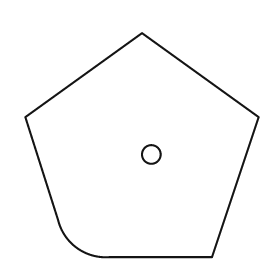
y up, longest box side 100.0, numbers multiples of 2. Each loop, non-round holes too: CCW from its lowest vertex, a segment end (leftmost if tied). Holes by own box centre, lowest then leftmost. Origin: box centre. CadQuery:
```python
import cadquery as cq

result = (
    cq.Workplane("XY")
    .moveTo(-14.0, -48.0)
    .lineTo(30.0, -48.0)
    .lineTo(50.0, 12.0)
    .lineTo(0.0, 48.0)
    .lineTo(-50.0, 12.0)
    .lineTo(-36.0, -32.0)
    .threePointArc((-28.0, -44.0), (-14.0, -48.0))
    .close()
    .moveTo(4.0, -4.0)
    .circle(4.0)
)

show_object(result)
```